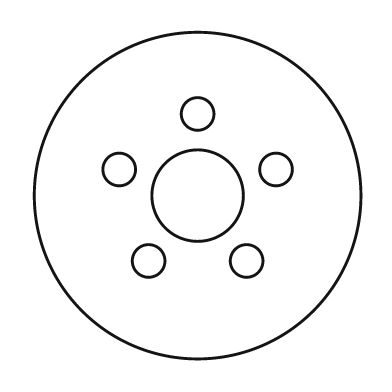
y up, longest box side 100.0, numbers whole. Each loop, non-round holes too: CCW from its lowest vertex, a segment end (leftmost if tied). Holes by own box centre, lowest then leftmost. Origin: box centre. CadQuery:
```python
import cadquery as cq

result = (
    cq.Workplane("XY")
    .moveTo(0.0, 0.0)
    .circle(50.0)
    .moveTo(-15.0, -20.0)
    .circle(5.0)
    .moveTo(15.0, -20.0)
    .circle(5.0)
    .moveTo(0.0, 0.0)
    .circle(14.0)
    .moveTo(-24.0, 8.0)
    .circle(5.0)
    .moveTo(24.0, 8.0)
    .circle(5.0)
    .moveTo(0.0, 25.0)
    .circle(5.0)
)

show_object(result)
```